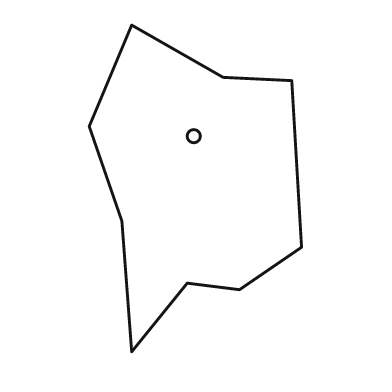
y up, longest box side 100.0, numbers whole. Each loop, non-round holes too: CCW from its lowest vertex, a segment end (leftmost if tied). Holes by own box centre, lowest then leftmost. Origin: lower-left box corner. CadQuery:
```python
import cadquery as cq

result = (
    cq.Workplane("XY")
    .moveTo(13.0, 0.0)
    .lineTo(30.0, 21.0)
    .lineTo(46.0, 19.0)
    .lineTo(65.0, 32.0)
    .lineTo(62.0, 83.0)
    .lineTo(41.0, 84.0)
    .lineTo(13.0, 100.0)
    .lineTo(0.0, 69.0)
    .lineTo(10.0, 40.0)
    .close()
    .moveTo(32.0, 66.0)
    .circle(2.0)
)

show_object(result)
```